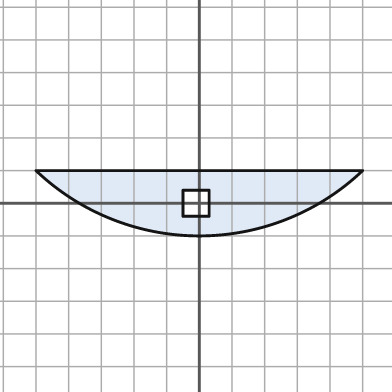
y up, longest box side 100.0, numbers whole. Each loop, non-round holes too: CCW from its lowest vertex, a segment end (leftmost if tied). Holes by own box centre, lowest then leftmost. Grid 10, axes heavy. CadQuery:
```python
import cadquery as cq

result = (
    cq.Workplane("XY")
    .moveTo(-50.0, 10.0)
    .threePointArc((0.0, -10.0), (50.0, 10.0))
    .close()
    .moveTo(-5.0, -4.0)
    .lineTo(3.0, -4.0)
    .lineTo(3.0, 4.0)
    .lineTo(-5.0, 4.0)
    .close()
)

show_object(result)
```